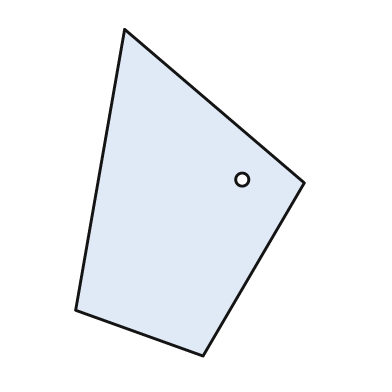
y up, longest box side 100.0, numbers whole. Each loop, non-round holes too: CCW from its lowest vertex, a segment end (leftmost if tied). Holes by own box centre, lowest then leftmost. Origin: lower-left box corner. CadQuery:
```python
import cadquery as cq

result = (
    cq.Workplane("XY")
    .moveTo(39.0, 0.0)
    .lineTo(70.0, 53.0)
    .lineTo(15.0, 100.0)
    .lineTo(0.0, 14.0)
    .close()
    .moveTo(51.0, 54.0)
    .circle(2.0)
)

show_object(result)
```